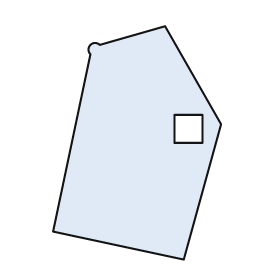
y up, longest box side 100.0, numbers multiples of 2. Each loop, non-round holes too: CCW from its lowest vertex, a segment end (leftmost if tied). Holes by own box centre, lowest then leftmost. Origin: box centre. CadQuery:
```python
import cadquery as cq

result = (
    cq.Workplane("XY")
    .moveTo(20.0, -50.0)
    .lineTo(36.0, 8.0)
    .lineTo(12.0, 50.0)
    .lineTo(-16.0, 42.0)
    .threePointArc((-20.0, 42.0), (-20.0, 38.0))
    .lineTo(-36.0, -38.0)
    .close()
    .moveTo(16.0, 0.0)
    .lineTo(28.0, 0.0)
    .lineTo(28.0, 12.0)
    .lineTo(16.0, 12.0)
    .close()
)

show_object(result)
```